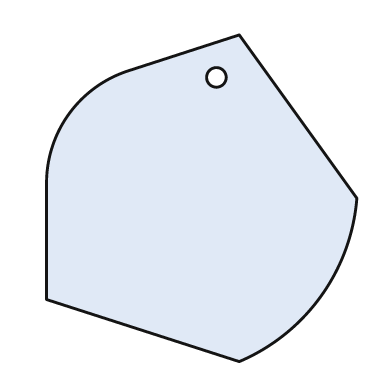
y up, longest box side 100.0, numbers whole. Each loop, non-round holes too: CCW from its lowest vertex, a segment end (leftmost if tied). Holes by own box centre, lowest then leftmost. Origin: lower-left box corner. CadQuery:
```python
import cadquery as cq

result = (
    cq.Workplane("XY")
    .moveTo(59.0, 0.0)
    .threePointArc((84.0, 20.0), (95.0, 50.0))
    .lineTo(59.0, 100.0)
    .lineTo(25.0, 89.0)
    .threePointArc((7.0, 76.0), (0.0, 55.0))
    .lineTo(0.0, 19.0)
    .close()
    .moveTo(52.0, 87.0)
    .circle(3.0)
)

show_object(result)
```